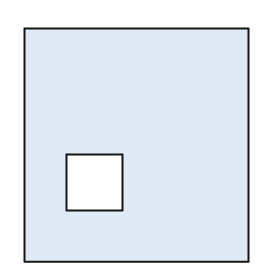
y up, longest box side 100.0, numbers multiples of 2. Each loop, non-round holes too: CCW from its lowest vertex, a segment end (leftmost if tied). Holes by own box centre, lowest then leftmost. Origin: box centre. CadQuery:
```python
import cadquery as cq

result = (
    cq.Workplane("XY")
    .moveTo(-48.0, -50.0)
    .lineTo(48.0, -50.0)
    .lineTo(48.0, 50.0)
    .lineTo(-48.0, 50.0)
    .close()
    .moveTo(-30.0, -28.0)
    .lineTo(-6.0, -28.0)
    .lineTo(-6.0, -4.0)
    .lineTo(-30.0, -4.0)
    .close()
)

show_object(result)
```